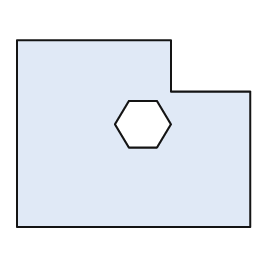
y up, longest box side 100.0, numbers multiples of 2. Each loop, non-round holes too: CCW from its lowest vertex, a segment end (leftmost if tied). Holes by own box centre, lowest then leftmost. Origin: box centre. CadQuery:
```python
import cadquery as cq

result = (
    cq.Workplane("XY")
    .moveTo(-50.0, -40.0)
    .lineTo(50.0, -40.0)
    .lineTo(50.0, 18.0)
    .lineTo(16.0, 18.0)
    .lineTo(16.0, 40.0)
    .lineTo(-50.0, 40.0)
    .close()
    .moveTo(-2.0, -6.0)
    .lineTo(10.0, -6.0)
    .lineTo(16.0, 4.0)
    .lineTo(10.0, 14.0)
    .lineTo(-2.0, 14.0)
    .lineTo(-8.0, 4.0)
    .close()
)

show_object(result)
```